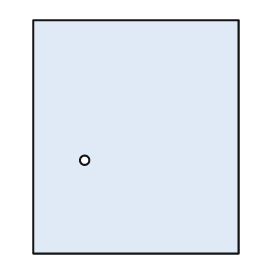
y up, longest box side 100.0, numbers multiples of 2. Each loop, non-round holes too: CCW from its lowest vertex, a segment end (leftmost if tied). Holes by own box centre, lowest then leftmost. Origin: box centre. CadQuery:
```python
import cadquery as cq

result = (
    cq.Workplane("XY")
    .moveTo(-44.0, -50.0)
    .lineTo(44.0, -50.0)
    .lineTo(44.0, 50.0)
    .lineTo(-44.0, 50.0)
    .close()
    .moveTo(-22.0, -10.0)
    .circle(2.0)
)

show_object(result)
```